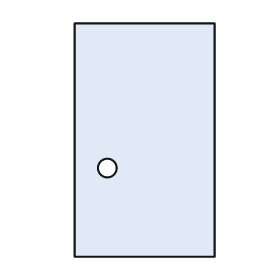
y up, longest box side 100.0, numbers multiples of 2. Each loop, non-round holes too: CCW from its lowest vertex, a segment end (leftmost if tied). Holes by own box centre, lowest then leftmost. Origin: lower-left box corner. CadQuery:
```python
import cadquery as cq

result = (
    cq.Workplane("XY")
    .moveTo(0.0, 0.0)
    .lineTo(60.0, 0.0)
    .lineTo(60.0, 100.0)
    .lineTo(0.0, 100.0)
    .close()
    .moveTo(14.0, 38.0)
    .circle(4.0)
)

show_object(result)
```